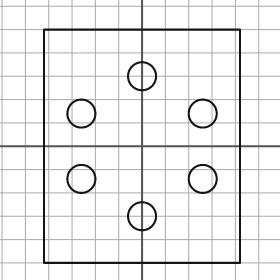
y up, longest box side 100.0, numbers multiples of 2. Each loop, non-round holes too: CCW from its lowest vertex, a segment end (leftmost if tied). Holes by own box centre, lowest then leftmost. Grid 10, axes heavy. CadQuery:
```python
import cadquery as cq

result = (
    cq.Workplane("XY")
    .moveTo(-42.0, -50.0)
    .lineTo(42.0, -50.0)
    .lineTo(42.0, 50.0)
    .lineTo(-42.0, 50.0)
    .close()
    .moveTo(0.0, -30.0)
    .circle(6.0)
    .moveTo(-26.0, -14.0)
    .circle(6.0)
    .moveTo(26.0, -14.0)
    .circle(6.0)
    .moveTo(-26.0, 14.0)
    .circle(6.0)
    .moveTo(26.0, 14.0)
    .circle(6.0)
    .moveTo(0.0, 30.0)
    .circle(6.0)
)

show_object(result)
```